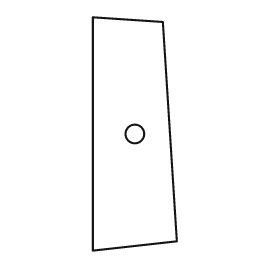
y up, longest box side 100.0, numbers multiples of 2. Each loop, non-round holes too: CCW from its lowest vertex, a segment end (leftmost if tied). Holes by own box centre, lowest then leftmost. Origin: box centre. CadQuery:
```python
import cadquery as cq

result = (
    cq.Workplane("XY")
    .moveTo(-18.0, -50.0)
    .lineTo(18.0, -46.0)
    .lineTo(12.0, 48.0)
    .lineTo(-18.0, 50.0)
    .close()
    .moveTo(0.0, 0.0)
    .circle(4.0)
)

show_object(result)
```